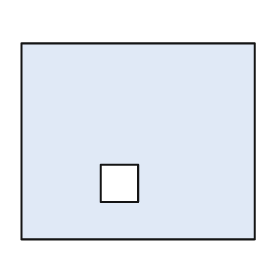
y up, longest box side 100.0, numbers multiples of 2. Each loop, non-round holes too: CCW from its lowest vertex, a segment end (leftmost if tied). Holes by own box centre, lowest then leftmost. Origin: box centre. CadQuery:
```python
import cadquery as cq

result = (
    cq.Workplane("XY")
    .moveTo(-50.0, -42.0)
    .lineTo(50.0, -42.0)
    .lineTo(50.0, 42.0)
    .lineTo(-50.0, 42.0)
    .close()
    .moveTo(-16.0, -26.0)
    .lineTo(0.0, -26.0)
    .lineTo(0.0, -10.0)
    .lineTo(-16.0, -10.0)
    .close()
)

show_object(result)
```